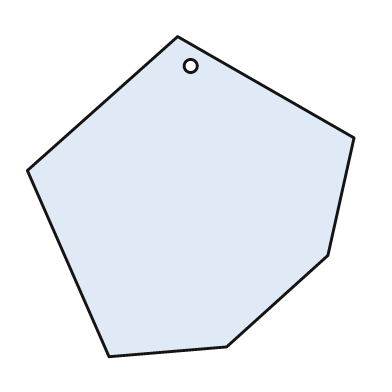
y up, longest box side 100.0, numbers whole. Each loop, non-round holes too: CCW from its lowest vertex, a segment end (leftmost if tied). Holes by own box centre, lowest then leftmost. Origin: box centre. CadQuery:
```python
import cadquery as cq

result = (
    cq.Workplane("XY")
    .moveTo(-25.0, -49.0)
    .lineTo(11.0, -46.0)
    .lineTo(42.0, -18.0)
    .lineTo(50.0, 18.0)
    .lineTo(-4.0, 49.0)
    .lineTo(-50.0, 8.0)
    .close()
    .moveTo(0.0, 40.0)
    .circle(2.0)
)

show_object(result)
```